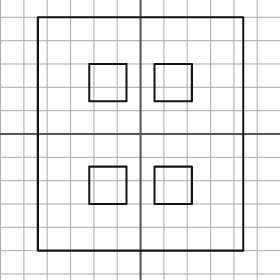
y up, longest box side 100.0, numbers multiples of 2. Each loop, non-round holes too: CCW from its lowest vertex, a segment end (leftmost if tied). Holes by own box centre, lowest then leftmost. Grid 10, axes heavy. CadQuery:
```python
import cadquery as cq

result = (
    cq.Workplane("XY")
    .moveTo(-44.0, -50.0)
    .lineTo(44.0, -50.0)
    .lineTo(44.0, 50.0)
    .lineTo(-44.0, 50.0)
    .close()
    .moveTo(-22.0, -30.0)
    .lineTo(-6.0, -30.0)
    .lineTo(-6.0, -14.0)
    .lineTo(-22.0, -14.0)
    .close()
    .moveTo(6.0, -30.0)
    .lineTo(22.0, -30.0)
    .lineTo(22.0, -14.0)
    .lineTo(6.0, -14.0)
    .close()
    .moveTo(-22.0, 14.0)
    .lineTo(-6.0, 14.0)
    .lineTo(-6.0, 30.0)
    .lineTo(-22.0, 30.0)
    .close()
    .moveTo(6.0, 14.0)
    .lineTo(22.0, 14.0)
    .lineTo(22.0, 30.0)
    .lineTo(6.0, 30.0)
    .close()
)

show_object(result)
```